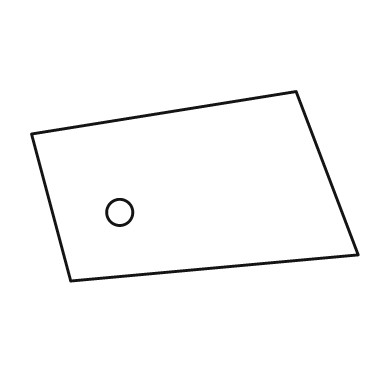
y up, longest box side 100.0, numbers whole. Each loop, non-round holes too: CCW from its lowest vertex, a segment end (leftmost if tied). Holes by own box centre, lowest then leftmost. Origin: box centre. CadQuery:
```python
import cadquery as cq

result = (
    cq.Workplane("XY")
    .moveTo(-38.0, -29.0)
    .lineTo(50.0, -21.0)
    .lineTo(31.0, 29.0)
    .lineTo(-50.0, 16.0)
    .close()
    .moveTo(-23.0, -8.0)
    .circle(4.0)
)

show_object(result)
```